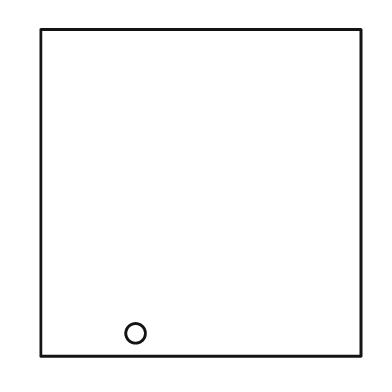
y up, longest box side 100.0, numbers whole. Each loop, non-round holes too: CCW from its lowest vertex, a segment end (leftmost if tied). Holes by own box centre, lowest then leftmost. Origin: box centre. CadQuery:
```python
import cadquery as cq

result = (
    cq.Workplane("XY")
    .moveTo(-49.0, -50.0)
    .lineTo(49.0, -50.0)
    .lineTo(49.0, 50.0)
    .lineTo(-49.0, 50.0)
    .close()
    .moveTo(-20.0, -43.0)
    .circle(3.0)
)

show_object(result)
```